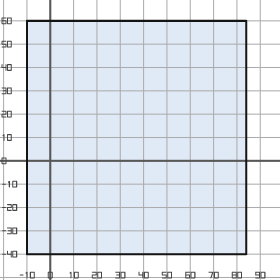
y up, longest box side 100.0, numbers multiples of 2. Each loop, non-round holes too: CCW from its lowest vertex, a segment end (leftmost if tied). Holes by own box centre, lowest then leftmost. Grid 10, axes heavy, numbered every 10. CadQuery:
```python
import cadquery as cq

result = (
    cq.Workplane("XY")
    .moveTo(-10.0, -40.0)
    .lineTo(84.0, -40.0)
    .lineTo(84.0, 60.0)
    .lineTo(-10.0, 60.0)
    .close()
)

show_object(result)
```